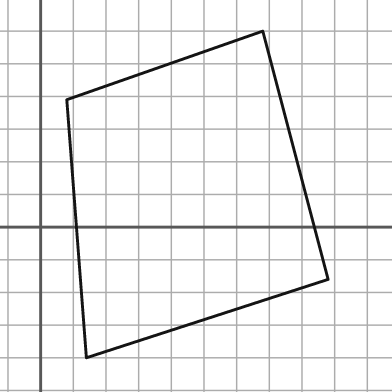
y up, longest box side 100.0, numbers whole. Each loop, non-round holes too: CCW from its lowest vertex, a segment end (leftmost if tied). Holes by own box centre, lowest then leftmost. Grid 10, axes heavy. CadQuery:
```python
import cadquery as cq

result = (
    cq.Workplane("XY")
    .moveTo(14.0, -40.0)
    .lineTo(88.0, -16.0)
    .lineTo(68.0, 60.0)
    .lineTo(8.0, 39.0)
    .close()
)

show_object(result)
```